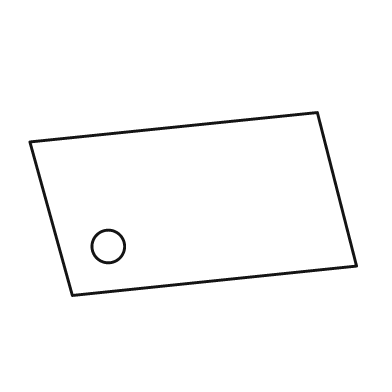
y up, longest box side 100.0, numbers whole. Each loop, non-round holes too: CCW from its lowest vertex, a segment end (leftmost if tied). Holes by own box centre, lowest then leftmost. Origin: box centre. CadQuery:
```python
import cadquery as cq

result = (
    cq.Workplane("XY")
    .moveTo(-37.0, -28.0)
    .lineTo(50.0, -19.0)
    .lineTo(38.0, 28.0)
    .lineTo(-50.0, 19.0)
    .close()
    .moveTo(-26.0, -13.0)
    .circle(5.0)
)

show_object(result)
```